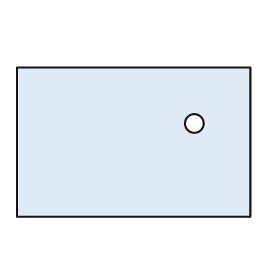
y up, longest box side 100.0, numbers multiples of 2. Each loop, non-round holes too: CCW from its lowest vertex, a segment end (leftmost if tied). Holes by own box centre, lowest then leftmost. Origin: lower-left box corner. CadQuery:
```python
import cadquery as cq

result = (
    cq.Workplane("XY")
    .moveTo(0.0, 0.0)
    .lineTo(100.0, 0.0)
    .lineTo(100.0, 64.0)
    .lineTo(0.0, 64.0)
    .close()
    .moveTo(76.0, 40.0)
    .circle(4.0)
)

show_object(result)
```